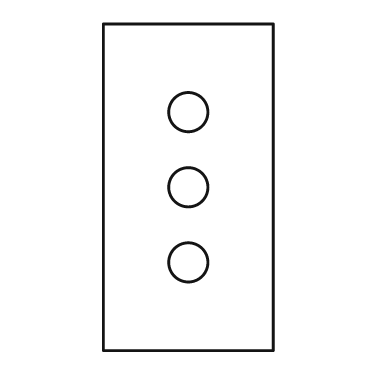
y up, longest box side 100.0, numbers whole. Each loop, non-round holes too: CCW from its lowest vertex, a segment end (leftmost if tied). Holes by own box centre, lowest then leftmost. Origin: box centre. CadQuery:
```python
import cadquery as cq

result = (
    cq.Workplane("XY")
    .moveTo(-26.0, -50.0)
    .lineTo(26.0, -50.0)
    .lineTo(26.0, 50.0)
    .lineTo(-26.0, 50.0)
    .close()
    .moveTo(0.0, -23.0)
    .circle(6.0)
    .moveTo(0.0, 0.0)
    .circle(6.0)
    .moveTo(0.0, 23.0)
    .circle(6.0)
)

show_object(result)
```